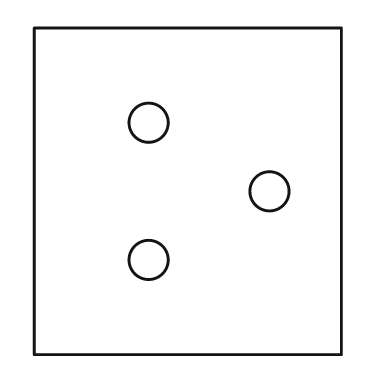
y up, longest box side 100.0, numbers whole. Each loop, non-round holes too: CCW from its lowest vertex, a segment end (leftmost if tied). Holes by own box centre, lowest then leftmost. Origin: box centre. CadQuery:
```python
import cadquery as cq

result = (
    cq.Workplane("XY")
    .moveTo(-47.0, -50.0)
    .lineTo(47.0, -50.0)
    .lineTo(47.0, 50.0)
    .lineTo(-47.0, 50.0)
    .close()
    .moveTo(-12.0, -21.0)
    .circle(6.0)
    .moveTo(25.0, 0.0)
    .circle(6.0)
    .moveTo(-12.0, 21.0)
    .circle(6.0)
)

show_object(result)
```